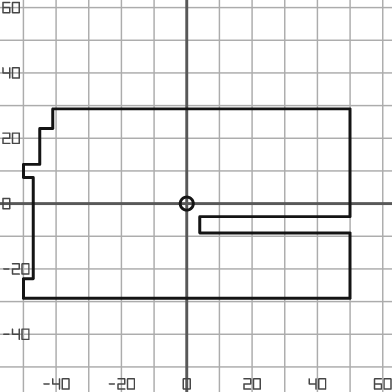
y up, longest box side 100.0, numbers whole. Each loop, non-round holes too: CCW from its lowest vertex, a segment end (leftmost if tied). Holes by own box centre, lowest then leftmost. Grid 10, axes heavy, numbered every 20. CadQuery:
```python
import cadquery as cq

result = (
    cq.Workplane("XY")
    .moveTo(-50.0, -29.0)
    .lineTo(50.0, -29.0)
    .lineTo(50.0, -9.0)
    .lineTo(4.0, -9.0)
    .lineTo(4.0, -4.0)
    .lineTo(50.0, -4.0)
    .lineTo(50.0, 29.0)
    .lineTo(-41.0, 29.0)
    .lineTo(-41.0, 23.0)
    .lineTo(-45.0, 23.0)
    .lineTo(-45.0, 12.0)
    .lineTo(-50.0, 12.0)
    .lineTo(-50.0, 8.0)
    .lineTo(-47.0, 8.0)
    .lineTo(-47.0, -23.0)
    .lineTo(-50.0, -23.0)
    .close()
    .moveTo(0.0, 0.0)
    .circle(2.0)
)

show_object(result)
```